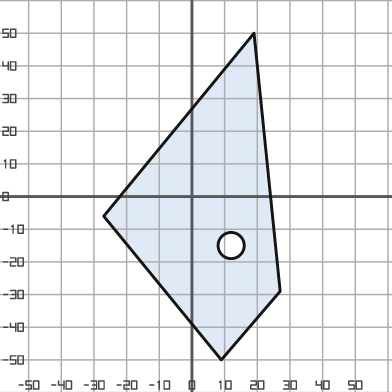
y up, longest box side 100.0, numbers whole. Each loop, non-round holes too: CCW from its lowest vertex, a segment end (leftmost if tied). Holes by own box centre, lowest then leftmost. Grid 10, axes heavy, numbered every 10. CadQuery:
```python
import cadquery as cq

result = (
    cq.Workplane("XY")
    .moveTo(9.0, -50.0)
    .lineTo(27.0, -29.0)
    .lineTo(19.0, 50.0)
    .lineTo(-27.0, -6.0)
    .close()
    .moveTo(12.0, -15.0)
    .circle(4.0)
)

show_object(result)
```